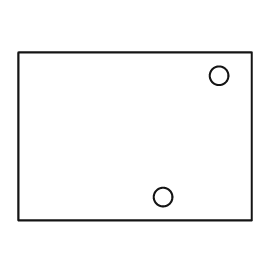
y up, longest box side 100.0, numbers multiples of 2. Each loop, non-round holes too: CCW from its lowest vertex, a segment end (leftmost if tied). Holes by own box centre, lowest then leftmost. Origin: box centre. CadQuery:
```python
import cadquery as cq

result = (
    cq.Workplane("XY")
    .moveTo(-50.0, -36.0)
    .lineTo(50.0, -36.0)
    .lineTo(50.0, 36.0)
    .lineTo(-50.0, 36.0)
    .close()
    .moveTo(12.0, -26.0)
    .circle(4.0)
    .moveTo(36.0, 26.0)
    .circle(4.0)
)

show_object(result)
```